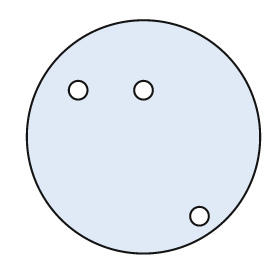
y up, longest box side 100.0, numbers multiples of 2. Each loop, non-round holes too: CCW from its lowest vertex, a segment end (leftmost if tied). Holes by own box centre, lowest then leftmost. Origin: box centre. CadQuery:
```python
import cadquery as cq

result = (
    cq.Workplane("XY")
    .moveTo(0.0, 0.0)
    .circle(50.0)
    .moveTo(24.0, -34.0)
    .circle(4.0)
    .moveTo(-28.0, 20.0)
    .circle(4.0)
    .moveTo(0.0, 20.0)
    .circle(4.0)
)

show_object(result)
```